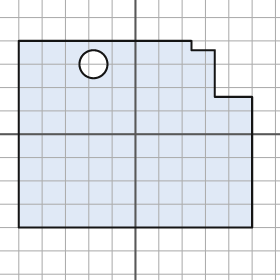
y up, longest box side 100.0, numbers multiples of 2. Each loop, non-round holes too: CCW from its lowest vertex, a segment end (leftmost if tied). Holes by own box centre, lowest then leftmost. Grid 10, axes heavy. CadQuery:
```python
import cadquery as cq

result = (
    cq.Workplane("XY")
    .moveTo(-50.0, -40.0)
    .lineTo(50.0, -40.0)
    .lineTo(50.0, 16.0)
    .lineTo(34.0, 16.0)
    .lineTo(34.0, 36.0)
    .lineTo(24.0, 36.0)
    .lineTo(24.0, 40.0)
    .lineTo(-50.0, 40.0)
    .close()
    .moveTo(-18.0, 30.0)
    .circle(6.0)
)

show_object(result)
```